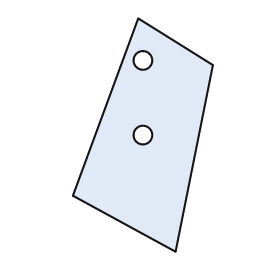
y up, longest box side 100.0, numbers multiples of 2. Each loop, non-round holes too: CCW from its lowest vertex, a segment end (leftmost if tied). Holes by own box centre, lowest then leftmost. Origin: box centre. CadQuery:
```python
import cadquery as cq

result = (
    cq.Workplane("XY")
    .moveTo(14.0, -50.0)
    .lineTo(30.0, 30.0)
    .lineTo(-2.0, 50.0)
    .lineTo(-30.0, -26.0)
    .close()
    .moveTo(0.0, 0.0)
    .circle(4.0)
    .moveTo(0.0, 32.0)
    .circle(4.0)
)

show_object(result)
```